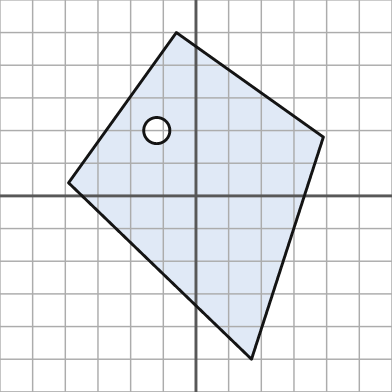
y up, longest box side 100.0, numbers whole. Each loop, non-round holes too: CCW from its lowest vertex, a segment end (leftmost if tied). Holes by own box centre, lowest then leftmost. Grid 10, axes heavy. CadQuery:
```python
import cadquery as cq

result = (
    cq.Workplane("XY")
    .moveTo(17.0, -50.0)
    .lineTo(39.0, 18.0)
    .lineTo(-6.0, 50.0)
    .lineTo(-39.0, 4.0)
    .close()
    .moveTo(-12.0, 20.0)
    .circle(4.0)
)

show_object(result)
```